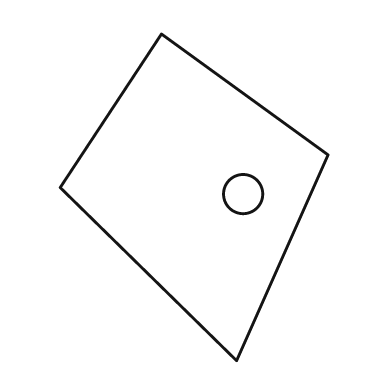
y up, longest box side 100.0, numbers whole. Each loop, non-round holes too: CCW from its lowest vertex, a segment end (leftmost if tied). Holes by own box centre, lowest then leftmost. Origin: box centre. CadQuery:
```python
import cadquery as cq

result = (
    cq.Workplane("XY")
    .moveTo(13.0, -50.0)
    .lineTo(41.0, 13.0)
    .lineTo(-10.0, 50.0)
    .lineTo(-41.0, 3.0)
    .close()
    .moveTo(15.0, 1.0)
    .circle(6.0)
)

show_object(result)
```